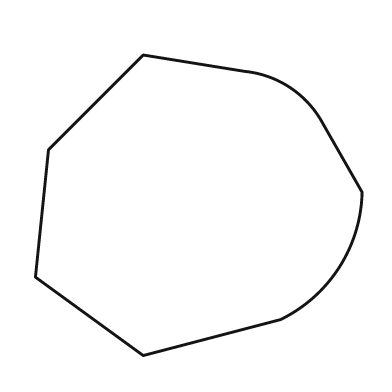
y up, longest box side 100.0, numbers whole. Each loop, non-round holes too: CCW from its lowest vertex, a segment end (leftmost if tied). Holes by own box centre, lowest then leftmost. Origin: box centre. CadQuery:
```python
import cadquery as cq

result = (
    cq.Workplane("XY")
    .moveTo(-17.0, -46.0)
    .lineTo(25.0, -35.0)
    .threePointArc((43.0, -19.0), (50.0, 4.0))
    .lineTo(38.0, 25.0)
    .threePointArc((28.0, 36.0), (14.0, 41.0))
    .lineTo(-17.0, 46.0)
    .lineTo(-46.0, 17.0)
    .lineTo(-50.0, -22.0)
    .close()
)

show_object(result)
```